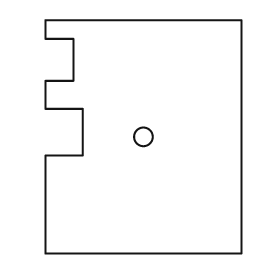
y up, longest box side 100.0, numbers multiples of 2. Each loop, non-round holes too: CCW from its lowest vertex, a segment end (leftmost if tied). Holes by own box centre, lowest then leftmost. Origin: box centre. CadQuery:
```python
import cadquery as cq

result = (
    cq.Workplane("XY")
    .moveTo(-42.0, -50.0)
    .lineTo(42.0, -50.0)
    .lineTo(42.0, 50.0)
    .lineTo(-42.0, 50.0)
    .lineTo(-42.0, 42.0)
    .lineTo(-30.0, 42.0)
    .lineTo(-30.0, 24.0)
    .lineTo(-42.0, 24.0)
    .lineTo(-42.0, 12.0)
    .lineTo(-26.0, 12.0)
    .lineTo(-26.0, -8.0)
    .lineTo(-42.0, -8.0)
    .close()
    .moveTo(0.0, 0.0)
    .circle(4.0)
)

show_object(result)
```